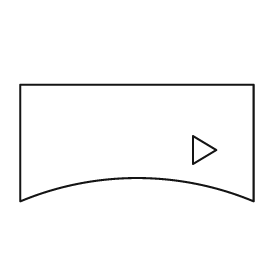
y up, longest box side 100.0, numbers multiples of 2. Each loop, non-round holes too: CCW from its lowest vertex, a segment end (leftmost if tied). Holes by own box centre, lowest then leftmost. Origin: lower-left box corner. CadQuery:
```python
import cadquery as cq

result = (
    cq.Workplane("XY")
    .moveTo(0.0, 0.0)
    .threePointArc((50.0, 10.0), (100.0, 0.0))
    .lineTo(100.0, 50.0)
    .lineTo(0.0, 50.0)
    .close()
    .moveTo(74.0, 16.0)
    .lineTo(84.0, 22.0)
    .lineTo(74.0, 28.0)
    .close()
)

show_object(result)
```